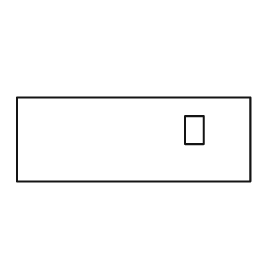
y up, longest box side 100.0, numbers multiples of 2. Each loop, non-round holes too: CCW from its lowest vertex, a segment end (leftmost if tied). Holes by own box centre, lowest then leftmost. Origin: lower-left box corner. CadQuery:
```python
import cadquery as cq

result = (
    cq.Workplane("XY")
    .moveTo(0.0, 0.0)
    .lineTo(100.0, 0.0)
    .lineTo(100.0, 36.0)
    .lineTo(0.0, 36.0)
    .close()
    .moveTo(72.0, 16.0)
    .lineTo(80.0, 16.0)
    .lineTo(80.0, 28.0)
    .lineTo(72.0, 28.0)
    .close()
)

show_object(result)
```